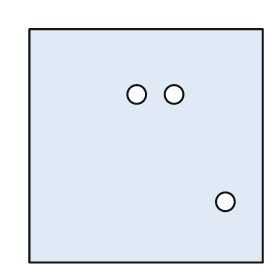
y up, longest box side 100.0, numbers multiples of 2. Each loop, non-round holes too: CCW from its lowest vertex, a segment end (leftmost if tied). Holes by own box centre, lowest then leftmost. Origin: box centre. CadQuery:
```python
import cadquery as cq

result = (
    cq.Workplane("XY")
    .moveTo(-50.0, -50.0)
    .lineTo(50.0, -50.0)
    .lineTo(50.0, 50.0)
    .lineTo(-50.0, 50.0)
    .close()
    .moveTo(34.0, -24.0)
    .circle(4.0)
    .moveTo(-4.0, 22.0)
    .circle(4.0)
    .moveTo(12.0, 22.0)
    .circle(4.0)
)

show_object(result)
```